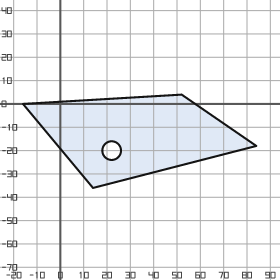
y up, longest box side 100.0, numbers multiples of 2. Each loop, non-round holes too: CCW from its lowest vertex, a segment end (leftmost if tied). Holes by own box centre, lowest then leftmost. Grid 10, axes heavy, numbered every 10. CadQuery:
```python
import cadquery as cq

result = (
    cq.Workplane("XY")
    .moveTo(14.0, -36.0)
    .lineTo(84.0, -18.0)
    .lineTo(52.0, 4.0)
    .lineTo(-16.0, 0.0)
    .close()
    .moveTo(22.0, -20.0)
    .circle(4.0)
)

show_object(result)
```